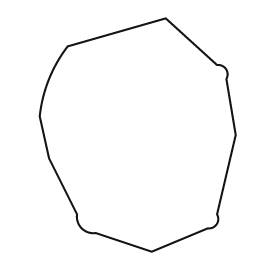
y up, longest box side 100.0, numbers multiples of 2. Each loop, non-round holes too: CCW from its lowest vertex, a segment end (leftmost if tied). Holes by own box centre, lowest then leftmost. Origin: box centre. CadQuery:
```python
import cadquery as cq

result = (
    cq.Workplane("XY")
    .moveTo(6.0, -50.0)
    .lineTo(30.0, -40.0)
    .threePointArc((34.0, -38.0), (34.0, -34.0))
    .lineTo(42.0, 0.0)
    .lineTo(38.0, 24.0)
    .threePointArc((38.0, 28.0), (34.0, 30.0))
    .lineTo(12.0, 50.0)
    .lineTo(-30.0, 38.0)
    .threePointArc((-38.0, 24.0), (-42.0, 8.0))
    .lineTo(-38.0, -10.0)
    .lineTo(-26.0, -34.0)
    .threePointArc((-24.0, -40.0), (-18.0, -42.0))
    .close()
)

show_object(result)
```